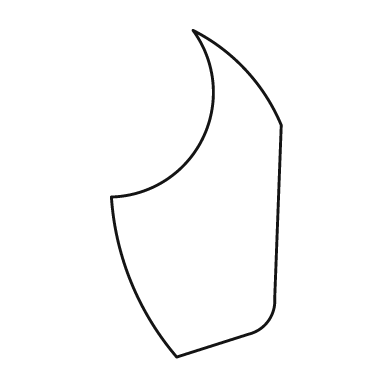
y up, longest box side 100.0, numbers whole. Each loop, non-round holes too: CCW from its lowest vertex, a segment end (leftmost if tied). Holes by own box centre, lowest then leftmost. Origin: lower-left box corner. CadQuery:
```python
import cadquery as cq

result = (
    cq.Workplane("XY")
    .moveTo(20.0, 0.0)
    .lineTo(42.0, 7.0)
    .threePointArc((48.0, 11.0), (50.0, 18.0))
    .lineTo(52.0, 71.0)
    .threePointArc((41.0, 88.0), (25.0, 100.0))
    .threePointArc((28.0, 67.0), (0.0, 49.0))
    .threePointArc((6.0, 23.0), (20.0, 0.0))
    .close()
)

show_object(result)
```